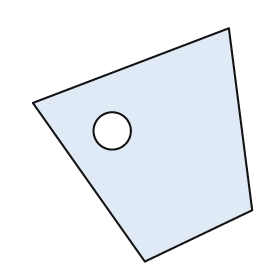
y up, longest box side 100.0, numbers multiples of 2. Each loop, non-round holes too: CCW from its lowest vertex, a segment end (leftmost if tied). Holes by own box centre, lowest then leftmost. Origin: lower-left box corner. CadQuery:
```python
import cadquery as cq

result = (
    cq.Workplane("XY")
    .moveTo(48.0, 0.0)
    .lineTo(94.0, 22.0)
    .lineTo(84.0, 100.0)
    .lineTo(0.0, 68.0)
    .close()
    .moveTo(34.0, 56.0)
    .circle(8.0)
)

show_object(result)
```